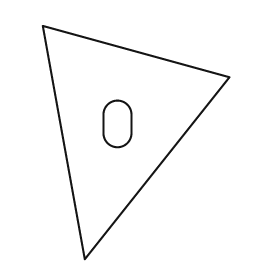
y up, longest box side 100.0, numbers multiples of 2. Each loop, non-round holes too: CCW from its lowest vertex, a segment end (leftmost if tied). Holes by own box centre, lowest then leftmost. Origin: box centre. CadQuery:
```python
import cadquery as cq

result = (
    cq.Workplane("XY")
    .moveTo(-22.0, -50.0)
    .lineTo(40.0, 28.0)
    .lineTo(-40.0, 50.0)
    .close()
    .moveTo(-14.0, 4.0)
    .threePointArc((-8.0, -2.0), (-2.0, 4.0))
    .lineTo(-2.0, 12.0)
    .threePointArc((-8.0, 18.0), (-14.0, 12.0))
    .close()
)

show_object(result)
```